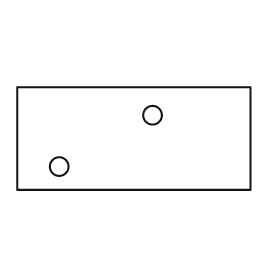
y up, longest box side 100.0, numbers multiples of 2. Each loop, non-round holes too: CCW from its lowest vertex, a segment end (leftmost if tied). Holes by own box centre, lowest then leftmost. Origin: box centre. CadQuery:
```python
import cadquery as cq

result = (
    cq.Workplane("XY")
    .moveTo(-50.0, -22.0)
    .lineTo(50.0, -22.0)
    .lineTo(50.0, 22.0)
    .lineTo(-50.0, 22.0)
    .close()
    .moveTo(-32.0, -12.0)
    .circle(4.0)
    .moveTo(8.0, 10.0)
    .circle(4.0)
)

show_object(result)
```